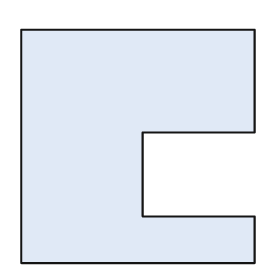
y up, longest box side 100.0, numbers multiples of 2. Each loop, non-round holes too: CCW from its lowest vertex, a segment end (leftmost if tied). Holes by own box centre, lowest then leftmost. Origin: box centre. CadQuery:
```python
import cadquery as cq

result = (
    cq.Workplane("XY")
    .moveTo(-50.0, -50.0)
    .lineTo(50.0, -50.0)
    .lineTo(50.0, -30.0)
    .lineTo(2.0, -30.0)
    .lineTo(2.0, 6.0)
    .lineTo(50.0, 6.0)
    .lineTo(50.0, 50.0)
    .lineTo(-50.0, 50.0)
    .close()
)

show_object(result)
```